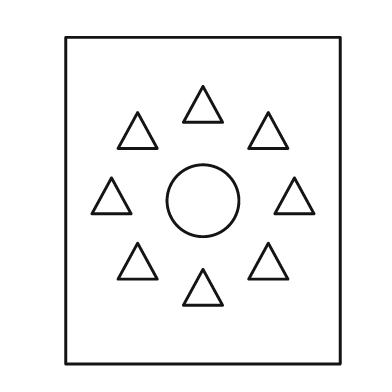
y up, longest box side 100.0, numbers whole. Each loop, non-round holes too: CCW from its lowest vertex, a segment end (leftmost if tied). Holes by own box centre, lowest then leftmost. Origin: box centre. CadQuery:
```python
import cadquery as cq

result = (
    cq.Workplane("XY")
    .moveTo(-42.0, -50.0)
    .lineTo(42.0, -50.0)
    .lineTo(42.0, 50.0)
    .lineTo(-42.0, 50.0)
    .close()
    .moveTo(-6.0, -32.0)
    .lineTo(6.0, -32.0)
    .lineTo(0.0, -21.0)
    .close()
    .moveTo(-26.0, -24.0)
    .lineTo(-14.0, -24.0)
    .lineTo(-20.0, -13.0)
    .close()
    .moveTo(14.0, -24.0)
    .lineTo(26.0, -24.0)
    .lineTo(20.0, -13.0)
    .close()
    .moveTo(0.0, 0.0)
    .circle(11.0)
    .moveTo(-34.0, -4.0)
    .lineTo(-22.0, -4.0)
    .lineTo(-28.0, 7.0)
    .close()
    .moveTo(22.0, -4.0)
    .lineTo(34.0, -4.0)
    .lineTo(28.0, 7.0)
    .close()
    .moveTo(-26.0, 16.0)
    .lineTo(-14.0, 16.0)
    .lineTo(-20.0, 27.0)
    .close()
    .moveTo(14.0, 16.0)
    .lineTo(26.0, 16.0)
    .lineTo(20.0, 27.0)
    .close()
    .moveTo(-6.0, 24.0)
    .lineTo(6.0, 24.0)
    .lineTo(0.0, 35.0)
    .close()
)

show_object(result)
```